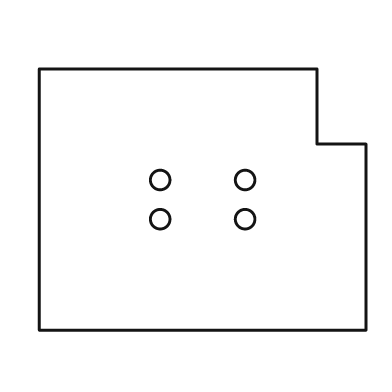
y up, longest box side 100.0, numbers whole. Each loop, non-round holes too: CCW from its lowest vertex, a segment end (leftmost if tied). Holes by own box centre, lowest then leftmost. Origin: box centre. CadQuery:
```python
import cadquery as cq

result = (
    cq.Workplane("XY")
    .moveTo(-50.0, -40.0)
    .lineTo(50.0, -40.0)
    .lineTo(50.0, 17.0)
    .lineTo(35.0, 17.0)
    .lineTo(35.0, 40.0)
    .lineTo(-50.0, 40.0)
    .close()
    .moveTo(-13.0, -6.0)
    .circle(3.0)
    .moveTo(13.0, -6.0)
    .circle(3.0)
    .moveTo(-13.0, 6.0)
    .circle(3.0)
    .moveTo(13.0, 6.0)
    .circle(3.0)
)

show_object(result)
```